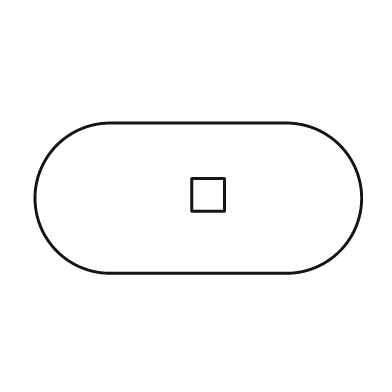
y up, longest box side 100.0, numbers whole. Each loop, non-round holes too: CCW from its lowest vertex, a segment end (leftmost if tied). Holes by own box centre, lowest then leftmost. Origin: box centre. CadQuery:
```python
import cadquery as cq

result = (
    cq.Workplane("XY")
    .moveTo(-27.0, -23.0)
    .lineTo(27.0, -23.0)
    .threePointArc((50.0, 0.0), (27.0, 23.0))
    .lineTo(-27.0, 23.0)
    .threePointArc((-50.0, 0.0), (-27.0, -23.0))
    .close()
    .moveTo(-2.0, -4.0)
    .lineTo(8.0, -4.0)
    .lineTo(8.0, 6.0)
    .lineTo(-2.0, 6.0)
    .close()
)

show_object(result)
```